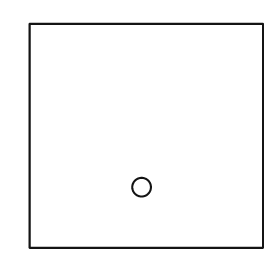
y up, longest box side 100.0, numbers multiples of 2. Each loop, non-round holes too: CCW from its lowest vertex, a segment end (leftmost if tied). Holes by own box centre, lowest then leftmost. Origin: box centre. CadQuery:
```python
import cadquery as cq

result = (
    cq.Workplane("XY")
    .moveTo(-50.0, -48.0)
    .lineTo(50.0, -48.0)
    .lineTo(50.0, 48.0)
    .lineTo(-50.0, 48.0)
    .close()
    .moveTo(-2.0, -22.0)
    .circle(4.0)
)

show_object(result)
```